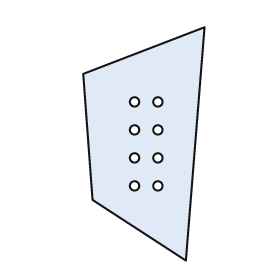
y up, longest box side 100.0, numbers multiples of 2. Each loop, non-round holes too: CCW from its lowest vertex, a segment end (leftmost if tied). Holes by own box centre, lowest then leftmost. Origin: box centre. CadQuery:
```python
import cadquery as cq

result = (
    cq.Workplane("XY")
    .moveTo(18.0, -50.0)
    .lineTo(26.0, 50.0)
    .lineTo(-26.0, 30.0)
    .lineTo(-22.0, -24.0)
    .close()
    .moveTo(-4.0, -18.0)
    .circle(2.0)
    .moveTo(6.0, -18.0)
    .circle(2.0)
    .moveTo(-4.0, -6.0)
    .circle(2.0)
    .moveTo(6.0, -6.0)
    .circle(2.0)
    .moveTo(-4.0, 6.0)
    .circle(2.0)
    .moveTo(6.0, 6.0)
    .circle(2.0)
    .moveTo(-4.0, 18.0)
    .circle(2.0)
    .moveTo(6.0, 18.0)
    .circle(2.0)
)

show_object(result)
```